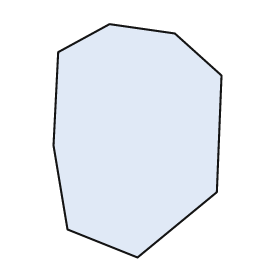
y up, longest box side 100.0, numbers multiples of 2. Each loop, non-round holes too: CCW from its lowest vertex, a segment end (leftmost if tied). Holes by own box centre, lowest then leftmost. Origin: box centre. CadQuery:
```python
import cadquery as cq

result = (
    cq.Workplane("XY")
    .moveTo(0.0, -50.0)
    .lineTo(34.0, -22.0)
    .lineTo(36.0, 28.0)
    .lineTo(16.0, 46.0)
    .lineTo(-12.0, 50.0)
    .lineTo(-34.0, 38.0)
    .lineTo(-36.0, -2.0)
    .lineTo(-30.0, -38.0)
    .close()
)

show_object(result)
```